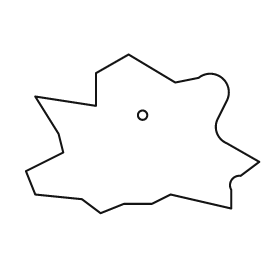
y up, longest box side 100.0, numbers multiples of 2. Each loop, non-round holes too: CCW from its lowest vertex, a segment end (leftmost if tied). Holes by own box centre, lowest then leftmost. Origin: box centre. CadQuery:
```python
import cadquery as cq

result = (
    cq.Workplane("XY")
    .moveTo(-18.0, -34.0)
    .lineTo(-8.0, -30.0)
    .lineTo(4.0, -30.0)
    .lineTo(12.0, -26.0)
    .lineTo(38.0, -32.0)
    .lineTo(38.0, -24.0)
    .threePointArc((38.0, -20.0), (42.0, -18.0))
    .lineTo(50.0, -12.0)
    .lineTo(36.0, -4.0)
    .threePointArc((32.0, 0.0), (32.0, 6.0))
    .lineTo(36.0, 14.0)
    .threePointArc((34.0, 24.0), (24.0, 24.0))
    .lineTo(14.0, 22.0)
    .lineTo(-6.0, 34.0)
    .lineTo(-20.0, 26.0)
    .lineTo(-20.0, 12.0)
    .lineTo(-46.0, 16.0)
    .lineTo(-36.0, 0.0)
    .lineTo(-34.0, -8.0)
    .lineTo(-50.0, -16.0)
    .lineTo(-46.0, -26.0)
    .lineTo(-26.0, -28.0)
    .close()
    .moveTo(0.0, 8.0)
    .circle(2.0)
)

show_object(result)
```